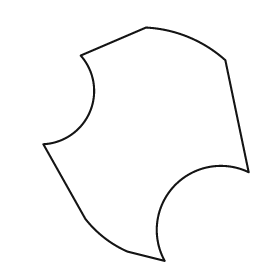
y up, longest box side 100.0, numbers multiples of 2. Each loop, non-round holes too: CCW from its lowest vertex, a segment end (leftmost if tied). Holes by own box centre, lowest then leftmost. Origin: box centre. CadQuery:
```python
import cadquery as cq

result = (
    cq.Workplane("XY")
    .moveTo(8.0, -50.0)
    .threePointArc((12.0, -18.0), (44.0, -12.0))
    .lineTo(34.0, 36.0)
    .threePointArc((18.0, 46.0), (0.0, 50.0))
    .lineTo(-28.0, 38.0)
    .threePointArc((-24.0, 14.0), (-44.0, 0.0))
    .lineTo(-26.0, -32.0)
    .threePointArc((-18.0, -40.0), (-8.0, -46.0))
    .close()
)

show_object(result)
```